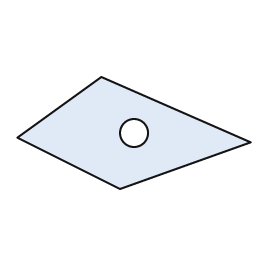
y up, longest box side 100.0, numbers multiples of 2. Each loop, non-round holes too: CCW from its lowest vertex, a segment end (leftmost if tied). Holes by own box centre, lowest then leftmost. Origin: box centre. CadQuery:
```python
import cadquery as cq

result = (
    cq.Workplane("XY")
    .moveTo(-6.0, -24.0)
    .lineTo(50.0, -4.0)
    .lineTo(-14.0, 24.0)
    .lineTo(-50.0, -2.0)
    .close()
    .moveTo(0.0, 0.0)
    .circle(6.0)
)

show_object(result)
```